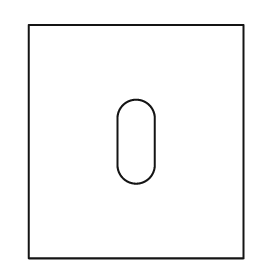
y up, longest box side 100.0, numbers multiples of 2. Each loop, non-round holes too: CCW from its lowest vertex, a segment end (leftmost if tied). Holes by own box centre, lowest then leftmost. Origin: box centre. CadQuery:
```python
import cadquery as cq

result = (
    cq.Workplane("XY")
    .moveTo(-46.0, -50.0)
    .lineTo(46.0, -50.0)
    .lineTo(46.0, 50.0)
    .lineTo(-46.0, 50.0)
    .close()
    .moveTo(-8.0, -10.0)
    .threePointArc((0.0, -18.0), (8.0, -10.0))
    .lineTo(8.0, 10.0)
    .threePointArc((0.0, 18.0), (-8.0, 10.0))
    .close()
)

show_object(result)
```